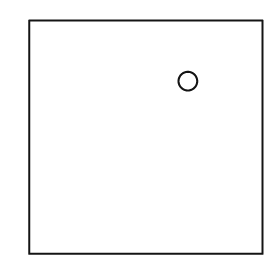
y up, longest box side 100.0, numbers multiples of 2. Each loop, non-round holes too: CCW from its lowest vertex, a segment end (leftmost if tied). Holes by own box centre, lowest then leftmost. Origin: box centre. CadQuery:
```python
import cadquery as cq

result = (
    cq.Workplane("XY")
    .moveTo(-50.0, -50.0)
    .lineTo(50.0, -50.0)
    .lineTo(50.0, 50.0)
    .lineTo(-50.0, 50.0)
    .close()
    .moveTo(18.0, 24.0)
    .circle(4.0)
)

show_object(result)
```